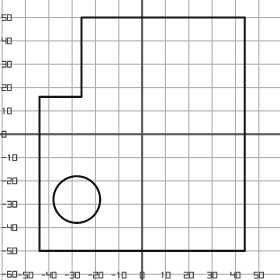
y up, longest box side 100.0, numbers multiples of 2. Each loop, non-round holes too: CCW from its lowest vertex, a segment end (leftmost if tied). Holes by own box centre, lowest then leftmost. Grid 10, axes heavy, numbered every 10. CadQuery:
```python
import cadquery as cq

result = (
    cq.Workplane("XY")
    .moveTo(-44.0, -50.0)
    .lineTo(44.0, -50.0)
    .lineTo(44.0, 50.0)
    .lineTo(-26.0, 50.0)
    .lineTo(-26.0, 16.0)
    .lineTo(-44.0, 16.0)
    .close()
    .moveTo(-28.0, -28.0)
    .circle(10.0)
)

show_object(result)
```